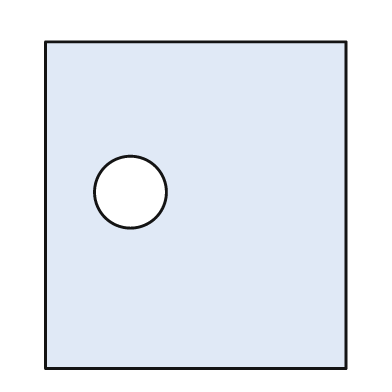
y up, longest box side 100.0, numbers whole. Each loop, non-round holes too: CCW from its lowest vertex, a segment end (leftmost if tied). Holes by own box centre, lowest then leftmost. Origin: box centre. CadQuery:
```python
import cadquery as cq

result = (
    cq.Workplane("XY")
    .moveTo(-46.0, -50.0)
    .lineTo(46.0, -50.0)
    .lineTo(46.0, 50.0)
    .lineTo(-46.0, 50.0)
    .close()
    .moveTo(-20.0, 4.0)
    .circle(11.0)
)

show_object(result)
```